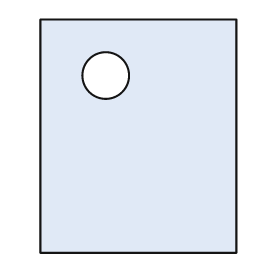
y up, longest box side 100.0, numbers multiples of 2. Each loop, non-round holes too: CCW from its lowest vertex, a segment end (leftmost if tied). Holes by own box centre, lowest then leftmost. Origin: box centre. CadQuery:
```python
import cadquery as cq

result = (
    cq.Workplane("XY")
    .moveTo(-42.0, -50.0)
    .lineTo(42.0, -50.0)
    .lineTo(42.0, 50.0)
    .lineTo(-42.0, 50.0)
    .close()
    .moveTo(-14.0, 26.0)
    .circle(10.0)
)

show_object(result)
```